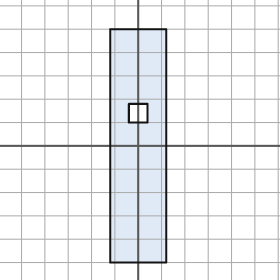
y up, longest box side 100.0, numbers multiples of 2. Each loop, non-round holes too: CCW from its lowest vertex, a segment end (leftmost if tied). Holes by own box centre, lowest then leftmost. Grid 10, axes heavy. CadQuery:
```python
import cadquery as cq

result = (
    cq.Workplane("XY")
    .moveTo(-12.0, -50.0)
    .lineTo(12.0, -50.0)
    .lineTo(12.0, 50.0)
    .lineTo(-12.0, 50.0)
    .close()
    .moveTo(-4.0, 10.0)
    .lineTo(4.0, 10.0)
    .lineTo(4.0, 18.0)
    .lineTo(-4.0, 18.0)
    .close()
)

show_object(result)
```